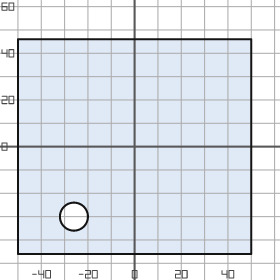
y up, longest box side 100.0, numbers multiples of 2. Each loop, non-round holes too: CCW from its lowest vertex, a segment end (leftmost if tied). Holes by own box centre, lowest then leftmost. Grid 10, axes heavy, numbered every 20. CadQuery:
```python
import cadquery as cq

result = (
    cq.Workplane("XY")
    .moveTo(-50.0, -46.0)
    .lineTo(50.0, -46.0)
    .lineTo(50.0, 46.0)
    .lineTo(-50.0, 46.0)
    .close()
    .moveTo(-26.0, -30.0)
    .circle(6.0)
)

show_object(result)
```